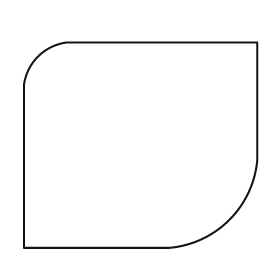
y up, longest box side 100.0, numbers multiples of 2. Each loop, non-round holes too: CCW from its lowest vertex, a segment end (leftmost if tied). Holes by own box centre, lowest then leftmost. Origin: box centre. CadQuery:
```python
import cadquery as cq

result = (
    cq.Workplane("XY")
    .moveTo(-50.0, -44.0)
    .lineTo(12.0, -44.0)
    .threePointArc((38.0, -32.0), (50.0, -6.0))
    .lineTo(50.0, 44.0)
    .lineTo(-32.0, 44.0)
    .threePointArc((-44.0, 38.0), (-50.0, 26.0))
    .close()
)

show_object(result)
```